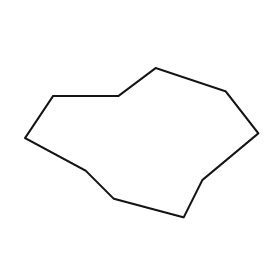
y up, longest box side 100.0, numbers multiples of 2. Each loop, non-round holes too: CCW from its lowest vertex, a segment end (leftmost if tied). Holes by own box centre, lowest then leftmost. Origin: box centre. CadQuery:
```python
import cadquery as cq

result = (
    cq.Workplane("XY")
    .moveTo(18.0, -32.0)
    .lineTo(26.0, -16.0)
    .lineTo(50.0, 4.0)
    .lineTo(36.0, 22.0)
    .lineTo(6.0, 32.0)
    .lineTo(-10.0, 20.0)
    .lineTo(-38.0, 20.0)
    .lineTo(-50.0, 2.0)
    .lineTo(-24.0, -12.0)
    .lineTo(-12.0, -24.0)
    .close()
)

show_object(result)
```